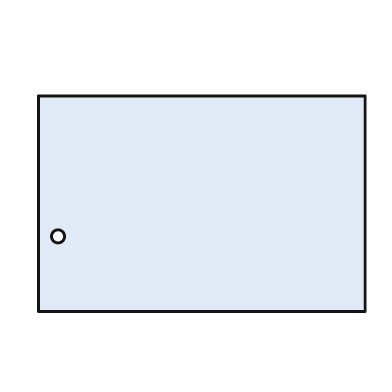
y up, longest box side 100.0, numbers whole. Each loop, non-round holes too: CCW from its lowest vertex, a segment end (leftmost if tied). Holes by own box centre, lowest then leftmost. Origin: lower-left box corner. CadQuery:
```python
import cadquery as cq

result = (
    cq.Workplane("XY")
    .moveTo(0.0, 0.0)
    .lineTo(100.0, 0.0)
    .lineTo(100.0, 66.0)
    .lineTo(0.0, 66.0)
    .close()
    .moveTo(6.0, 23.0)
    .circle(2.0)
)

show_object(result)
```